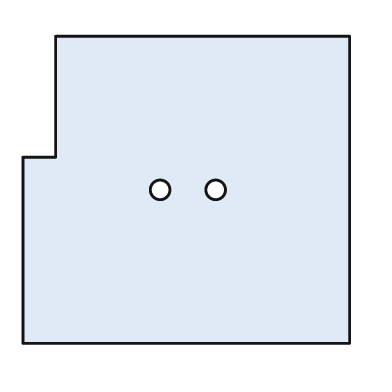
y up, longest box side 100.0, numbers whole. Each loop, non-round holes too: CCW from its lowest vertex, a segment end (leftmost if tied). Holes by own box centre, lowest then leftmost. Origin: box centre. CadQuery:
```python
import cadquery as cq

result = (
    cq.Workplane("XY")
    .moveTo(-50.0, -47.0)
    .lineTo(50.0, -47.0)
    .lineTo(50.0, 47.0)
    .lineTo(-40.0, 47.0)
    .lineTo(-40.0, 10.0)
    .lineTo(-50.0, 10.0)
    .close()
    .moveTo(-8.0, 0.0)
    .circle(3.0)
    .moveTo(9.0, 0.0)
    .circle(3.0)
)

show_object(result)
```